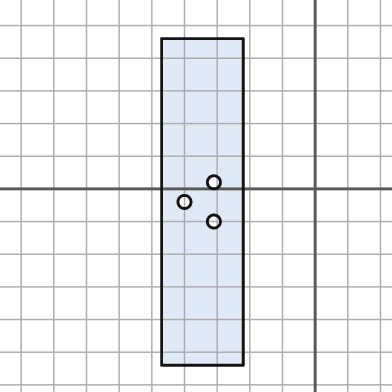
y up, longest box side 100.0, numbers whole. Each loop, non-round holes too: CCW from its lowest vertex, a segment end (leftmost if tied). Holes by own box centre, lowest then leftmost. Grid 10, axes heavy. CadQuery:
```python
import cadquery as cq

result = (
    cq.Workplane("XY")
    .moveTo(-47.0, -54.0)
    .lineTo(-22.0, -54.0)
    .lineTo(-22.0, 46.0)
    .lineTo(-47.0, 46.0)
    .close()
    .moveTo(-31.0, -10.0)
    .circle(2.0)
    .moveTo(-40.0, -4.0)
    .circle(2.0)
    .moveTo(-31.0, 2.0)
    .circle(2.0)
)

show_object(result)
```